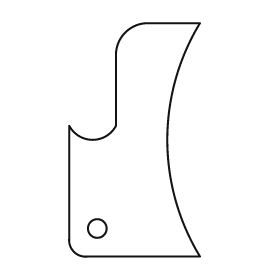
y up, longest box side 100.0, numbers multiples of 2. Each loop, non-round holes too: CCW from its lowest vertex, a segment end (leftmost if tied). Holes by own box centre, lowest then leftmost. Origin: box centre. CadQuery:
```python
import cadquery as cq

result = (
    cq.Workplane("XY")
    .moveTo(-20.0, -50.0)
    .lineTo(28.0, -50.0)
    .threePointArc((14.0, 0.0), (28.0, 50.0))
    .lineTo(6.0, 50.0)
    .threePointArc((-4.0, 46.0), (-8.0, 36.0))
    .lineTo(-8.0, 6.0)
    .threePointArc((-18.0, 0.0), (-28.0, 6.0))
    .lineTo(-28.0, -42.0)
    .threePointArc((-26.0, -48.0), (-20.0, -50.0))
    .close()
    .moveTo(-16.0, -38.0)
    .circle(4.0)
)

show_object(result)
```